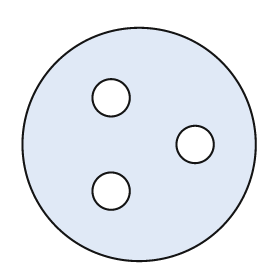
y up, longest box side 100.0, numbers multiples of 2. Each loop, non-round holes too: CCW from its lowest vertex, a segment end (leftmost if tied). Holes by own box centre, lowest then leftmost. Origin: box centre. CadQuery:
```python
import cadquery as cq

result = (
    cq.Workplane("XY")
    .moveTo(0.0, 0.0)
    .circle(50.0)
    .moveTo(-12.0, -20.0)
    .circle(8.0)
    .moveTo(24.0, 0.0)
    .circle(8.0)
    .moveTo(-12.0, 20.0)
    .circle(8.0)
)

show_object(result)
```